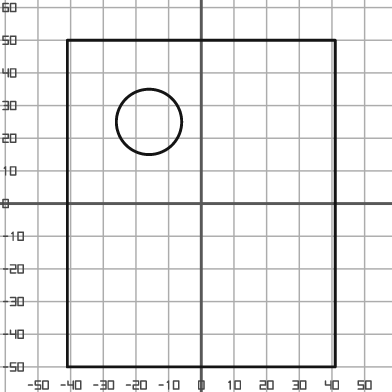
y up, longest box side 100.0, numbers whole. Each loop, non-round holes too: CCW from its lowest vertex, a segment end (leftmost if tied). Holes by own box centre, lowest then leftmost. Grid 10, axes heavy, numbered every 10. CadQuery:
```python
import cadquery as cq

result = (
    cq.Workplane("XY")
    .moveTo(-41.0, -50.0)
    .lineTo(41.0, -50.0)
    .lineTo(41.0, 50.0)
    .lineTo(-41.0, 50.0)
    .close()
    .moveTo(-16.0, 25.0)
    .circle(10.0)
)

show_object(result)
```